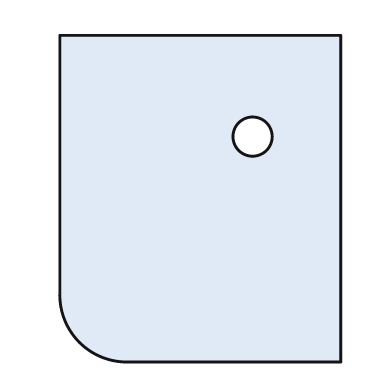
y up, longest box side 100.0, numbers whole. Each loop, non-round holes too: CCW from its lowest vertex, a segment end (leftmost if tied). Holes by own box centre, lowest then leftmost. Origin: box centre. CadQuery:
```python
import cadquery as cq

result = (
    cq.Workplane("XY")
    .moveTo(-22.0, -50.0)
    .lineTo(43.0, -50.0)
    .lineTo(43.0, 50.0)
    .lineTo(-43.0, 50.0)
    .lineTo(-43.0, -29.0)
    .threePointArc((-37.0, -44.0), (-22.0, -50.0))
    .close()
    .moveTo(16.0, 19.0)
    .circle(6.0)
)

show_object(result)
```